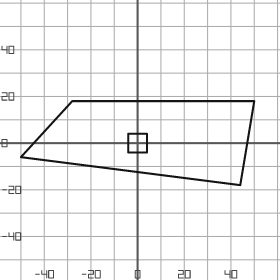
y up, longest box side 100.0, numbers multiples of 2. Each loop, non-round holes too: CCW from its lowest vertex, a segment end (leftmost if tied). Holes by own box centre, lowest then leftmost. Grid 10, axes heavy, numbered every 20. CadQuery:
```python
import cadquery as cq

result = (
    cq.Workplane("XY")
    .moveTo(44.0, -18.0)
    .lineTo(50.0, 18.0)
    .lineTo(-28.0, 18.0)
    .lineTo(-50.0, -6.0)
    .close()
    .moveTo(-4.0, -4.0)
    .lineTo(4.0, -4.0)
    .lineTo(4.0, 4.0)
    .lineTo(-4.0, 4.0)
    .close()
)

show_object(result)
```